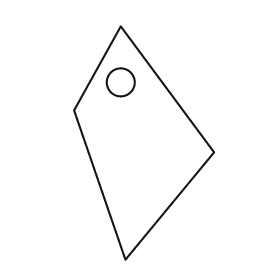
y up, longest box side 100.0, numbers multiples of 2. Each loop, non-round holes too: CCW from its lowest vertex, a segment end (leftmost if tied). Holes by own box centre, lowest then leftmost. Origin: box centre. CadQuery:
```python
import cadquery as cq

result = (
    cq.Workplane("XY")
    .moveTo(-8.0, -50.0)
    .lineTo(30.0, -4.0)
    .lineTo(-10.0, 50.0)
    .lineTo(-30.0, 14.0)
    .close()
    .moveTo(-10.0, 26.0)
    .circle(6.0)
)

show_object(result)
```